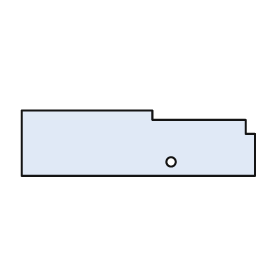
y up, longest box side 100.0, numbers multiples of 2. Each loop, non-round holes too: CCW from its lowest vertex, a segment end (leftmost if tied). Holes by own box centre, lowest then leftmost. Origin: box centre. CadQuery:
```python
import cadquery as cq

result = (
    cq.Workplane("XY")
    .moveTo(-50.0, -14.0)
    .lineTo(50.0, -14.0)
    .lineTo(50.0, 4.0)
    .lineTo(46.0, 4.0)
    .lineTo(46.0, 10.0)
    .lineTo(6.0, 10.0)
    .lineTo(6.0, 14.0)
    .lineTo(-50.0, 14.0)
    .close()
    .moveTo(14.0, -8.0)
    .circle(2.0)
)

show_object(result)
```